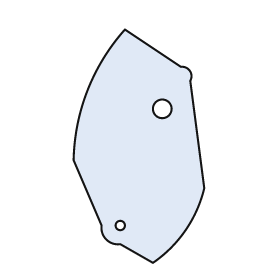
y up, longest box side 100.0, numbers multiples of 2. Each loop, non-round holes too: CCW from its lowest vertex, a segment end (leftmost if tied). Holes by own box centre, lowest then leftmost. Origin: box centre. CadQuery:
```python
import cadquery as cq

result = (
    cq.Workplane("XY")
    .moveTo(6.0, -50.0)
    .threePointArc((20.0, -36.0), (28.0, -18.0))
    .lineTo(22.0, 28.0)
    .threePointArc((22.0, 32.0), (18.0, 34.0))
    .lineTo(-6.0, 50.0)
    .threePointArc((-22.0, 24.0), (-28.0, -6.0))
    .lineTo(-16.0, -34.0)
    .threePointArc((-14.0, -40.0), (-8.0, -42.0))
    .close()
    .moveTo(-8.0, -34.0)
    .circle(2.0)
    .moveTo(10.0, 16.0)
    .circle(4.0)
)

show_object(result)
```